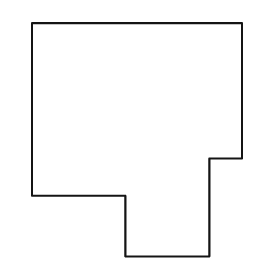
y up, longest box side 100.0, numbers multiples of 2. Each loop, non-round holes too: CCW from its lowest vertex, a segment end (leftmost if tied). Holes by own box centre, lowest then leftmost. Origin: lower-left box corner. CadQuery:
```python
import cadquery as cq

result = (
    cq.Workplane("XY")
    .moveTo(40.0, 0.0)
    .lineTo(76.0, 0.0)
    .lineTo(76.0, 42.0)
    .lineTo(90.0, 42.0)
    .lineTo(90.0, 100.0)
    .lineTo(0.0, 100.0)
    .lineTo(0.0, 26.0)
    .lineTo(40.0, 26.0)
    .close()
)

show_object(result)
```